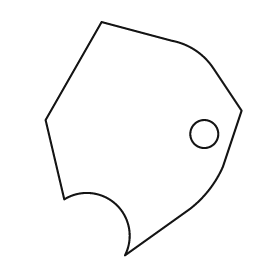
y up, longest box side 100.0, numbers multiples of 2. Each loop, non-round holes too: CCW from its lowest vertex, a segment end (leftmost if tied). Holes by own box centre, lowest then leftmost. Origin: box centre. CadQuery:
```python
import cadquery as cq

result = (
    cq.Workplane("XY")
    .moveTo(-8.0, -50.0)
    .lineTo(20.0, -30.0)
    .threePointArc((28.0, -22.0), (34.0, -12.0))
    .lineTo(42.0, 12.0)
    .lineTo(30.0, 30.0)
    .threePointArc((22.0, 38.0), (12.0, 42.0))
    .lineTo(-18.0, 50.0)
    .lineTo(-42.0, 8.0)
    .lineTo(-34.0, -26.0)
    .threePointArc((-12.0, -28.0), (-8.0, -50.0))
    .close()
    .moveTo(26.0, 2.0)
    .circle(6.0)
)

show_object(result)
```